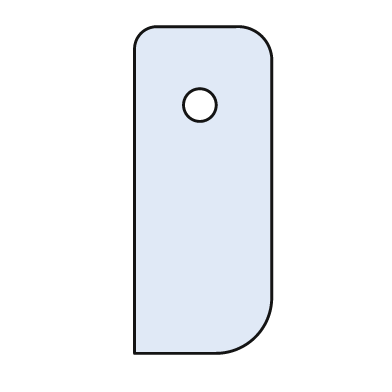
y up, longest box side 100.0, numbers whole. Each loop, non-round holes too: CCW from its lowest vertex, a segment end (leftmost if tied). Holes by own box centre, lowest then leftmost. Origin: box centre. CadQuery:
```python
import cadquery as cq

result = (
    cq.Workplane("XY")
    .moveTo(-21.0, -50.0)
    .lineTo(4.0, -50.0)
    .threePointArc((16.0, -45.0), (21.0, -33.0))
    .lineTo(21.0, 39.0)
    .threePointArc((18.0, 47.0), (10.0, 50.0))
    .lineTo(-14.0, 50.0)
    .threePointArc((-19.0, 48.0), (-21.0, 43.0))
    .close()
    .moveTo(-1.0, 26.0)
    .circle(5.0)
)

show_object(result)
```